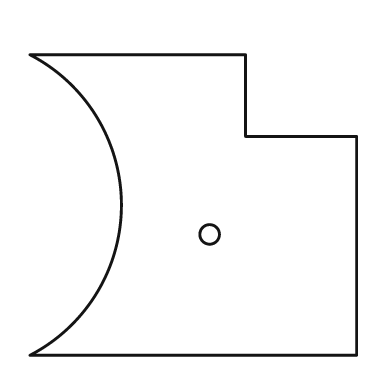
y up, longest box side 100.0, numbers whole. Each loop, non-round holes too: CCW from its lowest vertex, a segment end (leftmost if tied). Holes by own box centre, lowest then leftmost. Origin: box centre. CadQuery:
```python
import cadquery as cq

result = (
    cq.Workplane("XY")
    .moveTo(-50.0, -46.0)
    .lineTo(50.0, -46.0)
    .lineTo(50.0, 21.0)
    .lineTo(16.0, 21.0)
    .lineTo(16.0, 46.0)
    .lineTo(-50.0, 46.0)
    .threePointArc((-22.0, 0.0), (-50.0, -46.0))
    .close()
    .moveTo(5.0, -9.0)
    .circle(3.0)
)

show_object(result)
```